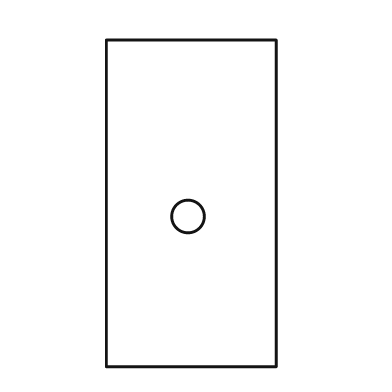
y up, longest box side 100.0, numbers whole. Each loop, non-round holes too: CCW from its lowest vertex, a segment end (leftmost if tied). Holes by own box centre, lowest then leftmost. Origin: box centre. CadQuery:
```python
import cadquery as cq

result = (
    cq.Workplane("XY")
    .moveTo(-26.0, -50.0)
    .lineTo(26.0, -50.0)
    .lineTo(26.0, 50.0)
    .lineTo(-26.0, 50.0)
    .close()
    .moveTo(-1.0, -4.0)
    .circle(5.0)
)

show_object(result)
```